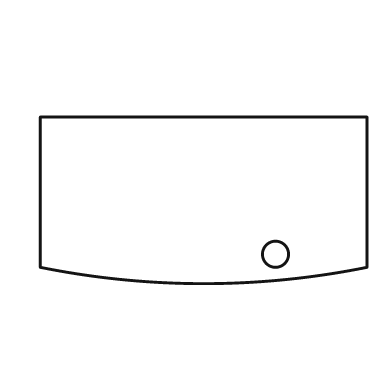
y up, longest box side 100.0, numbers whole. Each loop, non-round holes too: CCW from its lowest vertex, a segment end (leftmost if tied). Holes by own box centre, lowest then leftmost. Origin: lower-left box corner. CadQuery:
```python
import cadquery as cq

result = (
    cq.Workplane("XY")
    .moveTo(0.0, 5.0)
    .threePointArc((50.0, 0.0), (100.0, 5.0))
    .lineTo(100.0, 51.0)
    .lineTo(0.0, 51.0)
    .close()
    .moveTo(72.0, 9.0)
    .circle(4.0)
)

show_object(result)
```